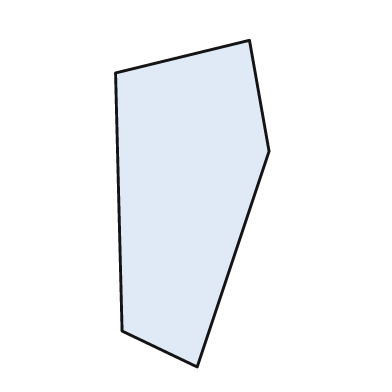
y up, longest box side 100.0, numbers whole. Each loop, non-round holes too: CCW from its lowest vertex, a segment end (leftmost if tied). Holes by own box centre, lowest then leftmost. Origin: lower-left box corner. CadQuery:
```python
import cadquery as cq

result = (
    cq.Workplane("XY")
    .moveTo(25.0, 0.0)
    .lineTo(47.0, 66.0)
    .lineTo(41.0, 100.0)
    .lineTo(0.0, 90.0)
    .lineTo(2.0, 11.0)
    .close()
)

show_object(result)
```